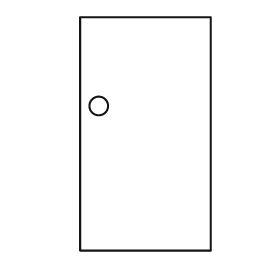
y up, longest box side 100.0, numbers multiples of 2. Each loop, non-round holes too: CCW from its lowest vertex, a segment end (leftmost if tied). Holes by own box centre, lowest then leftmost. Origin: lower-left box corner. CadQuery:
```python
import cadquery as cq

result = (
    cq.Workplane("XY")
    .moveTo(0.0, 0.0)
    .lineTo(56.0, 0.0)
    .lineTo(56.0, 100.0)
    .lineTo(0.0, 100.0)
    .close()
    .moveTo(8.0, 62.0)
    .circle(4.0)
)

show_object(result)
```